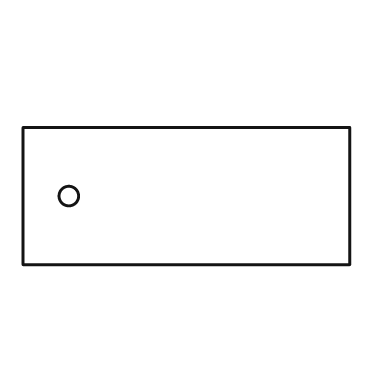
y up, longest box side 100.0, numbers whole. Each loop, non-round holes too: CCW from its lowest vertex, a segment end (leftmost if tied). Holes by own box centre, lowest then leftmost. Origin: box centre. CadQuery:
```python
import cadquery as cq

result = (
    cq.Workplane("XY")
    .moveTo(-50.0, -21.0)
    .lineTo(50.0, -21.0)
    .lineTo(50.0, 21.0)
    .lineTo(-50.0, 21.0)
    .close()
    .moveTo(-36.0, 0.0)
    .circle(3.0)
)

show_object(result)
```